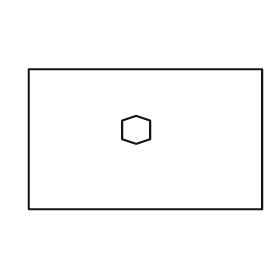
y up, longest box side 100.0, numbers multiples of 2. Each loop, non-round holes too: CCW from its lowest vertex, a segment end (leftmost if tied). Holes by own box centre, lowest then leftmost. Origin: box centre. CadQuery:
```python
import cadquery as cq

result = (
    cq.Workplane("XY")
    .moveTo(-50.0, -30.0)
    .lineTo(50.0, -30.0)
    .lineTo(50.0, 30.0)
    .lineTo(-50.0, 30.0)
    .close()
    .moveTo(-4.0, -2.0)
    .lineTo(2.0, 0.0)
    .lineTo(2.0, 8.0)
    .lineTo(-4.0, 10.0)
    .lineTo(-10.0, 8.0)
    .lineTo(-10.0, 0.0)
    .close()
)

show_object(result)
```